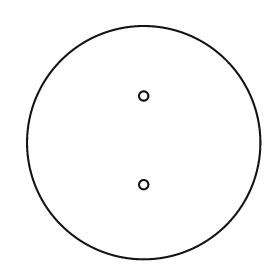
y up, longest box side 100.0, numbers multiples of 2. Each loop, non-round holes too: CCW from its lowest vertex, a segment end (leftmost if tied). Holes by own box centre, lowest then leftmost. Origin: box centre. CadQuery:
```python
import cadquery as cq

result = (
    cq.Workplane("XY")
    .moveTo(0.0, 0.0)
    .circle(50.0)
    .moveTo(0.0, -18.0)
    .circle(2.0)
    .moveTo(0.0, 20.0)
    .circle(2.0)
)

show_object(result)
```